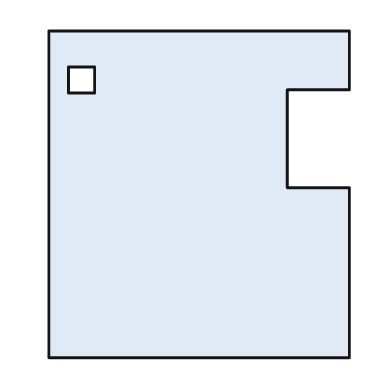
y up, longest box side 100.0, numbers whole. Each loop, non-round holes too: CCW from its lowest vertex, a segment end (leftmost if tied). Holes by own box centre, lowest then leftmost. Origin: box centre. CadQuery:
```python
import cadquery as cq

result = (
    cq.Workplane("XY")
    .moveTo(-46.0, -50.0)
    .lineTo(46.0, -50.0)
    .lineTo(46.0, 2.0)
    .lineTo(27.0, 2.0)
    .lineTo(27.0, 32.0)
    .lineTo(46.0, 32.0)
    .lineTo(46.0, 50.0)
    .lineTo(-46.0, 50.0)
    .close()
    .moveTo(-40.0, 31.0)
    .lineTo(-32.0, 31.0)
    .lineTo(-32.0, 39.0)
    .lineTo(-40.0, 39.0)
    .close()
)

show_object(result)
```